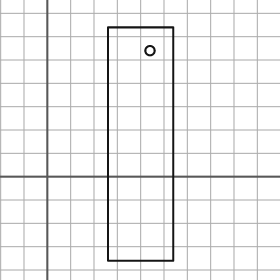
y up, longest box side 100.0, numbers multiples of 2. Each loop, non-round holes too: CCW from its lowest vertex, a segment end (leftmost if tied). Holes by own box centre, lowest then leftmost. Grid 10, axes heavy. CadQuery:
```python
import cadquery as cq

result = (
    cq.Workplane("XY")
    .moveTo(26.0, -36.0)
    .lineTo(54.0, -36.0)
    .lineTo(54.0, 64.0)
    .lineTo(26.0, 64.0)
    .close()
    .moveTo(44.0, 54.0)
    .circle(2.0)
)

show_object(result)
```